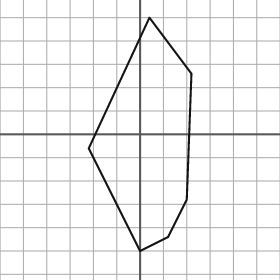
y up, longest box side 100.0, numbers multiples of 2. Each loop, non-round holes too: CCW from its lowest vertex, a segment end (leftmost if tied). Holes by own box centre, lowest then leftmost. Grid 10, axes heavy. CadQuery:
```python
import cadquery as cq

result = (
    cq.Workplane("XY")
    .moveTo(0.0, -50.0)
    .lineTo(12.0, -44.0)
    .lineTo(20.0, -28.0)
    .lineTo(22.0, 26.0)
    .lineTo(4.0, 50.0)
    .lineTo(-22.0, -6.0)
    .close()
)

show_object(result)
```